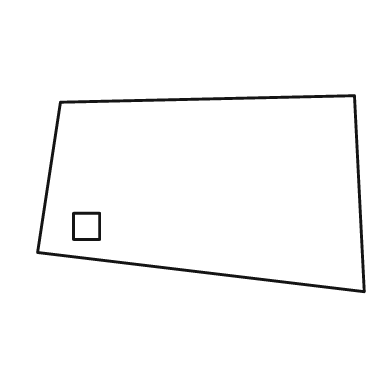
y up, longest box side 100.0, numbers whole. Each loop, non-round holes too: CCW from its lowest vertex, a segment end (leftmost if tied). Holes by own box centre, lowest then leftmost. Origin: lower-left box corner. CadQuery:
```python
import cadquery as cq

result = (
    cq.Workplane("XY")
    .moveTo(100.0, 0.0)
    .lineTo(97.0, 60.0)
    .lineTo(7.0, 58.0)
    .lineTo(0.0, 12.0)
    .close()
    .moveTo(11.0, 16.0)
    .lineTo(19.0, 16.0)
    .lineTo(19.0, 24.0)
    .lineTo(11.0, 24.0)
    .close()
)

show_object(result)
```